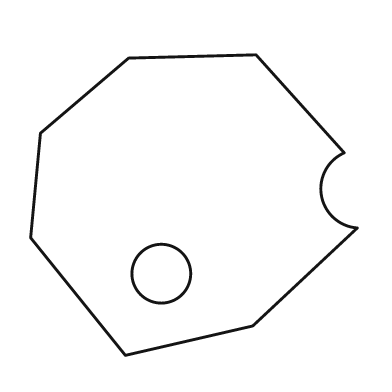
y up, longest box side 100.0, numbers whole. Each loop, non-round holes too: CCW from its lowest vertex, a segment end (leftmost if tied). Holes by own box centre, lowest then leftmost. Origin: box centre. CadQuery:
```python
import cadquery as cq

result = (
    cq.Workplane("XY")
    .moveTo(-21.0, -46.0)
    .lineTo(18.0, -37.0)
    .lineTo(50.0, -7.0)
    .threePointArc((39.0, 3.0), (46.0, 16.0))
    .lineTo(19.0, 46.0)
    .lineTo(-20.0, 45.0)
    .lineTo(-47.0, 22.0)
    .lineTo(-50.0, -10.0)
    .close()
    .moveTo(-10.0, -21.0)
    .circle(9.0)
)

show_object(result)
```